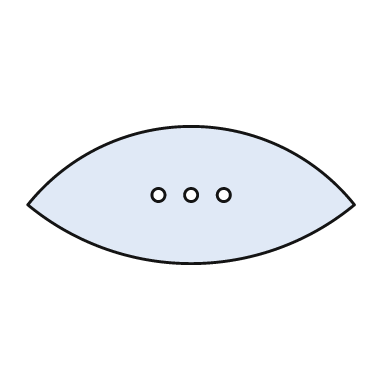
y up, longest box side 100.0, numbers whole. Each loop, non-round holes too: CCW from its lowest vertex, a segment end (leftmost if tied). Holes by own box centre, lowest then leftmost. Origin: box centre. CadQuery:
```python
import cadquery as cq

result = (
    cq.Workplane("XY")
    .moveTo(-50.0, -3.0)
    .threePointArc((0.0, -21.0), (50.0, -3.0))
    .threePointArc((0.0, 21.0), (-50.0, -3.0))
    .close()
    .moveTo(-10.0, 0.0)
    .circle(2.0)
    .moveTo(0.0, 0.0)
    .circle(2.0)
    .moveTo(10.0, 0.0)
    .circle(2.0)
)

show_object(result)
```